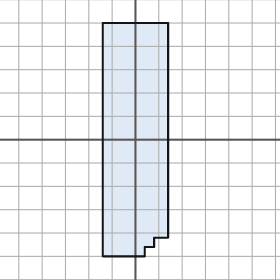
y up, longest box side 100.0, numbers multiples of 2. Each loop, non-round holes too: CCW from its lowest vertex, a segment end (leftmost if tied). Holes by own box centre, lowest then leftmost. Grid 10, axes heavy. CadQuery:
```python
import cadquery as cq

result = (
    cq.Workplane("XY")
    .moveTo(-14.0, -50.0)
    .lineTo(4.0, -50.0)
    .lineTo(4.0, -46.0)
    .lineTo(8.0, -46.0)
    .lineTo(8.0, -42.0)
    .lineTo(14.0, -42.0)
    .lineTo(14.0, 50.0)
    .lineTo(-14.0, 50.0)
    .close()
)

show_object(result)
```